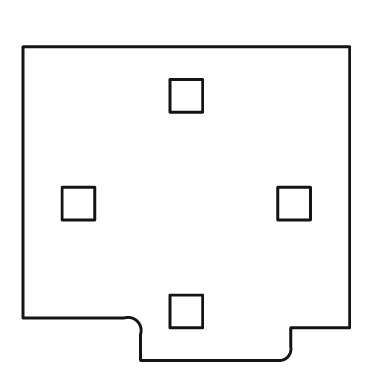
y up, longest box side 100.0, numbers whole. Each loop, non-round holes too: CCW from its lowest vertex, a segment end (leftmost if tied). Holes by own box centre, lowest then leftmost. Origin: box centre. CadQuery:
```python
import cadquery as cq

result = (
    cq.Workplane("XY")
    .moveTo(-14.0, -48.0)
    .lineTo(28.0, -48.0)
    .threePointArc((31.0, -47.0), (32.0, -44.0))
    .lineTo(32.0, -38.0)
    .lineTo(50.0, -38.0)
    .lineTo(50.0, 48.0)
    .lineTo(-50.0, 48.0)
    .lineTo(-50.0, -35.0)
    .lineTo(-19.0, -35.0)
    .threePointArc((-15.0, -36.0), (-14.0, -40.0))
    .close()
    .moveTo(-5.0, -38.0)
    .lineTo(5.0, -38.0)
    .lineTo(5.0, -28.0)
    .lineTo(-5.0, -28.0)
    .close()
    .moveTo(-38.0, -5.0)
    .lineTo(-28.0, -5.0)
    .lineTo(-28.0, 5.0)
    .lineTo(-38.0, 5.0)
    .close()
    .moveTo(28.0, -5.0)
    .lineTo(38.0, -5.0)
    .lineTo(38.0, 5.0)
    .lineTo(28.0, 5.0)
    .close()
    .moveTo(-5.0, 28.0)
    .lineTo(5.0, 28.0)
    .lineTo(5.0, 38.0)
    .lineTo(-5.0, 38.0)
    .close()
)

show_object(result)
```